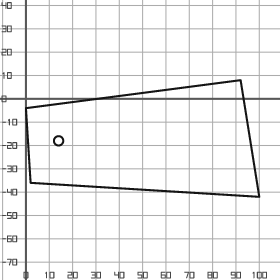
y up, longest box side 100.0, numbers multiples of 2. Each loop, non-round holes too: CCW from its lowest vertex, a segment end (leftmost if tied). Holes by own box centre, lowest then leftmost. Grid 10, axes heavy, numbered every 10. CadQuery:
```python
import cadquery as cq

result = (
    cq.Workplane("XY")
    .moveTo(100.0, -42.0)
    .lineTo(92.0, 8.0)
    .lineTo(0.0, -4.0)
    .lineTo(2.0, -36.0)
    .close()
    .moveTo(14.0, -18.0)
    .circle(2.0)
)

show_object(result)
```